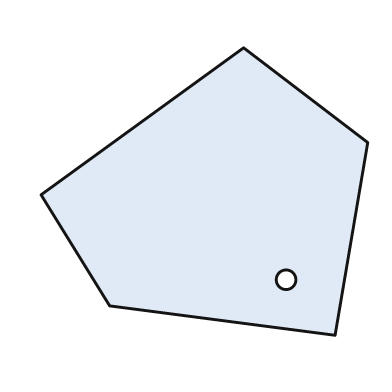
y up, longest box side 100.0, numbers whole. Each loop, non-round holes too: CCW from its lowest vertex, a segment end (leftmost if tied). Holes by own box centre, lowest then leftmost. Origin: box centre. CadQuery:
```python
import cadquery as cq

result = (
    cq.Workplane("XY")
    .moveTo(40.0, -44.0)
    .lineTo(50.0, 15.0)
    .lineTo(12.0, 44.0)
    .lineTo(-50.0, -1.0)
    .lineTo(-29.0, -35.0)
    .close()
    .moveTo(25.0, -27.0)
    .circle(3.0)
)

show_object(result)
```